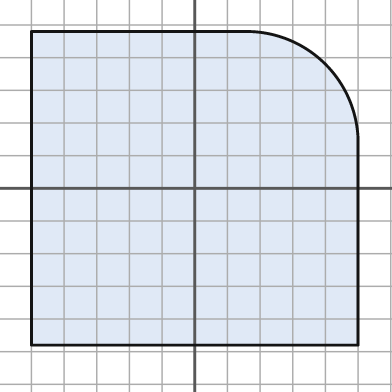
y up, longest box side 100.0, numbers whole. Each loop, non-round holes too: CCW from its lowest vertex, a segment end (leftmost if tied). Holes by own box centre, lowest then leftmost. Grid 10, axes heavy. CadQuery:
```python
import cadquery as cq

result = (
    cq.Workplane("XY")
    .moveTo(-50.0, -48.0)
    .lineTo(50.0, -48.0)
    .lineTo(50.0, 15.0)
    .threePointArc((40.0, 38.0), (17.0, 48.0))
    .lineTo(-50.0, 48.0)
    .close()
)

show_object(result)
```